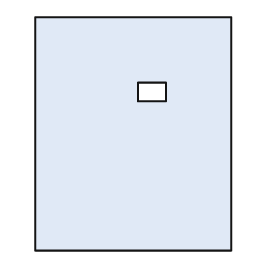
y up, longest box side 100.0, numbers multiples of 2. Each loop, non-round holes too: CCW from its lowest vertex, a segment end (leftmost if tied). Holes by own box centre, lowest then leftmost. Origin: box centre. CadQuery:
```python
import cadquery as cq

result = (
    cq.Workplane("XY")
    .moveTo(-42.0, -50.0)
    .lineTo(42.0, -50.0)
    .lineTo(42.0, 50.0)
    .lineTo(-42.0, 50.0)
    .close()
    .moveTo(2.0, 14.0)
    .lineTo(14.0, 14.0)
    .lineTo(14.0, 22.0)
    .lineTo(2.0, 22.0)
    .close()
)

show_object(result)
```